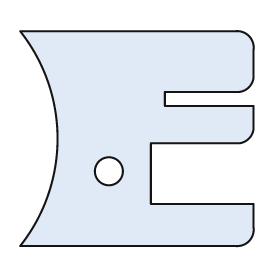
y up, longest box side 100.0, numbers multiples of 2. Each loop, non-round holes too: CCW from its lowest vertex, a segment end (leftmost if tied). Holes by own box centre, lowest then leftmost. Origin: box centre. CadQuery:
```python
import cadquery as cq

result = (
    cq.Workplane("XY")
    .moveTo(-50.0, -46.0)
    .lineTo(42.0, -46.0)
    .threePointArc((48.0, -44.0), (50.0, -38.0))
    .lineTo(50.0, -28.0)
    .lineTo(6.0, -28.0)
    .lineTo(6.0, -2.0)
    .lineTo(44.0, -2.0)
    .threePointArc((48.0, 0.0), (50.0, 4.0))
    .lineTo(50.0, 14.0)
    .lineTo(12.0, 14.0)
    .lineTo(12.0, 20.0)
    .lineTo(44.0, 20.0)
    .threePointArc((48.0, 22.0), (50.0, 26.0))
    .lineTo(50.0, 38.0)
    .threePointArc((48.0, 44.0), (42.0, 46.0))
    .lineTo(-50.0, 46.0)
    .threePointArc((-34.0, 0.0), (-50.0, -46.0))
    .close()
    .moveTo(-12.0, -14.0)
    .circle(6.0)
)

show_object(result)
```